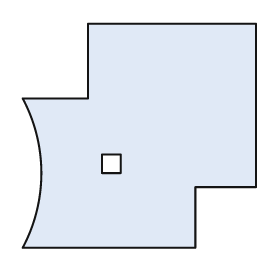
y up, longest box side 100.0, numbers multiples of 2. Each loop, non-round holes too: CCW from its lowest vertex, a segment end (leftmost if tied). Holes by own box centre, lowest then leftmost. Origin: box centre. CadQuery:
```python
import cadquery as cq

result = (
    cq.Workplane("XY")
    .moveTo(-50.0, -48.0)
    .lineTo(24.0, -48.0)
    .lineTo(24.0, -22.0)
    .lineTo(50.0, -22.0)
    .lineTo(50.0, 48.0)
    .lineTo(-22.0, 48.0)
    .lineTo(-22.0, 16.0)
    .lineTo(-50.0, 16.0)
    .threePointArc((-42.0, -16.0), (-50.0, -48.0))
    .close()
    .moveTo(-16.0, -16.0)
    .lineTo(-8.0, -16.0)
    .lineTo(-8.0, -8.0)
    .lineTo(-16.0, -8.0)
    .close()
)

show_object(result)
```